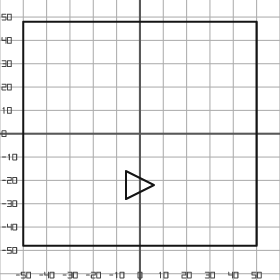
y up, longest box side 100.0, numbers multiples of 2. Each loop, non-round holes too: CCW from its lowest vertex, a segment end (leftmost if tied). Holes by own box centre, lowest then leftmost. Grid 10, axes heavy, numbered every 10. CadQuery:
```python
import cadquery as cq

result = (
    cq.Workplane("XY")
    .moveTo(-50.0, -48.0)
    .lineTo(50.0, -48.0)
    .lineTo(50.0, 48.0)
    .lineTo(-50.0, 48.0)
    .close()
    .moveTo(-6.0, -28.0)
    .lineTo(6.0, -22.0)
    .lineTo(-6.0, -16.0)
    .close()
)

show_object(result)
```